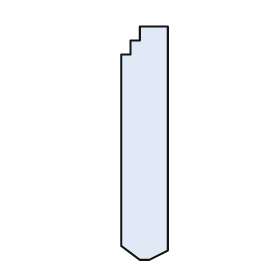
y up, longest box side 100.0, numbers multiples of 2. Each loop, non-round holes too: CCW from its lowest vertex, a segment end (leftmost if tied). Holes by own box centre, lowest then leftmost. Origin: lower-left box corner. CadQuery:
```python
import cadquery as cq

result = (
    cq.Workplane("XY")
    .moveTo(8.0, 0.0)
    .lineTo(12.0, 0.0)
    .lineTo(20.0, 4.0)
    .lineTo(20.0, 100.0)
    .lineTo(8.0, 100.0)
    .lineTo(8.0, 94.0)
    .lineTo(4.0, 94.0)
    .lineTo(4.0, 88.0)
    .lineTo(0.0, 88.0)
    .lineTo(0.0, 6.0)
    .close()
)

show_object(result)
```